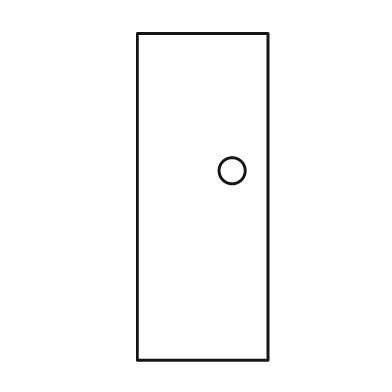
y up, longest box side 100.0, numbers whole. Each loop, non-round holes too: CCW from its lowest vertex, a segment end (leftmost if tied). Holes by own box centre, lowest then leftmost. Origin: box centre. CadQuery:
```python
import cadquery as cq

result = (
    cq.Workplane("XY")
    .moveTo(-20.0, -50.0)
    .lineTo(20.0, -50.0)
    .lineTo(20.0, 50.0)
    .lineTo(-20.0, 50.0)
    .close()
    .moveTo(9.0, 8.0)
    .circle(4.0)
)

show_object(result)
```